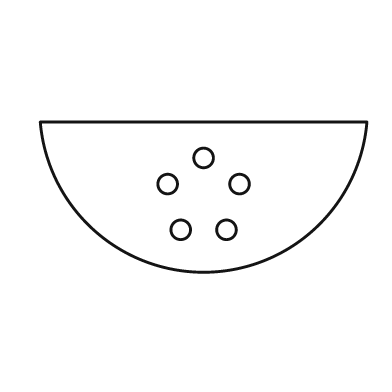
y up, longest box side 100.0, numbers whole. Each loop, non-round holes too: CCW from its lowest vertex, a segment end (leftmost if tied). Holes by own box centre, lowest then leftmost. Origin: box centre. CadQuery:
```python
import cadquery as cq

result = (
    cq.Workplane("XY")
    .moveTo(-50.0, 23.0)
    .threePointArc((0.0, -23.0), (50.0, 23.0))
    .close()
    .moveTo(-7.0, -10.0)
    .circle(3.0)
    .moveTo(7.0, -10.0)
    .circle(3.0)
    .moveTo(-11.0, 4.0)
    .circle(3.0)
    .moveTo(11.0, 4.0)
    .circle(3.0)
    .moveTo(0.0, 12.0)
    .circle(3.0)
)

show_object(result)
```